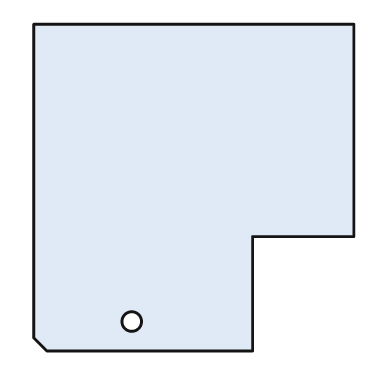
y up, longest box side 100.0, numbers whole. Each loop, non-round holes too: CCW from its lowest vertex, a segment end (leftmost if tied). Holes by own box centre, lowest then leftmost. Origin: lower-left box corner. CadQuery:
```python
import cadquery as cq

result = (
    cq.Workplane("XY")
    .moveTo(4.0, 0.0)
    .lineTo(67.0, 0.0)
    .lineTo(67.0, 35.0)
    .lineTo(98.0, 35.0)
    .lineTo(98.0, 100.0)
    .lineTo(0.0, 100.0)
    .lineTo(0.0, 4.0)
    .close()
    .moveTo(30.0, 9.0)
    .circle(3.0)
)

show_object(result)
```